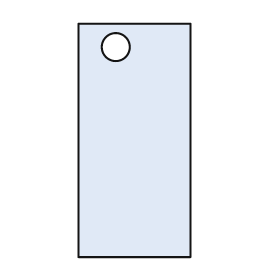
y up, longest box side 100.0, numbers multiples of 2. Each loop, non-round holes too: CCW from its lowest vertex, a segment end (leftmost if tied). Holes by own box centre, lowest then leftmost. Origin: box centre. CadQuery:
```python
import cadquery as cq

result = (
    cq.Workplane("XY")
    .moveTo(-24.0, -50.0)
    .lineTo(24.0, -50.0)
    .lineTo(24.0, 50.0)
    .lineTo(-24.0, 50.0)
    .close()
    .moveTo(-8.0, 40.0)
    .circle(6.0)
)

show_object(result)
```